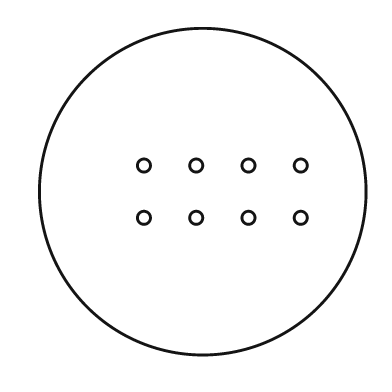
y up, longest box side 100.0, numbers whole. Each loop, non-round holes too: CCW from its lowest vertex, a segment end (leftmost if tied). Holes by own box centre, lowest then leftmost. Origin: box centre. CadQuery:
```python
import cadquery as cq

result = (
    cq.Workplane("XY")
    .moveTo(0.0, 0.0)
    .circle(50.0)
    .moveTo(-18.0, -8.0)
    .circle(2.0)
    .moveTo(-2.0, -8.0)
    .circle(2.0)
    .moveTo(14.0, -8.0)
    .circle(2.0)
    .moveTo(30.0, -8.0)
    .circle(2.0)
    .moveTo(-18.0, 8.0)
    .circle(2.0)
    .moveTo(-2.0, 8.0)
    .circle(2.0)
    .moveTo(14.0, 8.0)
    .circle(2.0)
    .moveTo(30.0, 8.0)
    .circle(2.0)
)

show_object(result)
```